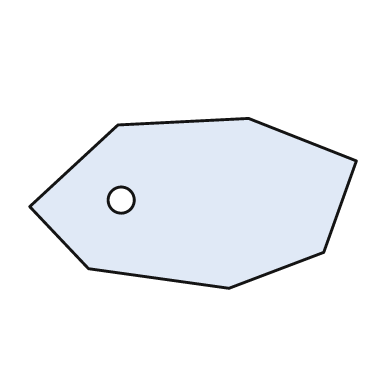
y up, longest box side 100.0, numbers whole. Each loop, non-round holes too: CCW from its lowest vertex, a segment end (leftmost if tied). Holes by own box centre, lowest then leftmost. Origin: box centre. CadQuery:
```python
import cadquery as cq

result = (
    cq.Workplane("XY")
    .moveTo(11.0, -26.0)
    .lineTo(40.0, -15.0)
    .lineTo(50.0, 13.0)
    .lineTo(17.0, 26.0)
    .lineTo(-23.0, 24.0)
    .lineTo(-50.0, -1.0)
    .lineTo(-32.0, -20.0)
    .close()
    .moveTo(-22.0, 1.0)
    .circle(4.0)
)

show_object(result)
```